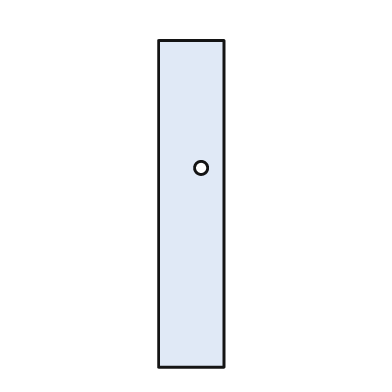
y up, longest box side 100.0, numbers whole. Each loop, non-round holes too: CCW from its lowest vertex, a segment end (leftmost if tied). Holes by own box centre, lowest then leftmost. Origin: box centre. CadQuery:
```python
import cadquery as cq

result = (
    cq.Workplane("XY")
    .moveTo(-10.0, -50.0)
    .lineTo(10.0, -50.0)
    .lineTo(10.0, 50.0)
    .lineTo(-10.0, 50.0)
    .close()
    .moveTo(3.0, 11.0)
    .circle(2.0)
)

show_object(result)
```